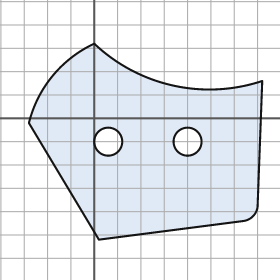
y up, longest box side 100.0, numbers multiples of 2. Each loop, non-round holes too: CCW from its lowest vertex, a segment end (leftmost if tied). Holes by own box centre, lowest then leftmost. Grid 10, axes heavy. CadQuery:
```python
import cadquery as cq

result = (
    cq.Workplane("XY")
    .moveTo(2.0, -52.0)
    .lineTo(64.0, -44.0)
    .threePointArc((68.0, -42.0), (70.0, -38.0))
    .lineTo(72.0, 16.0)
    .threePointArc((34.0, 14.0), (0.0, 32.0))
    .threePointArc((-18.0, 18.0), (-28.0, -2.0))
    .close()
    .moveTo(6.0, -10.0)
    .circle(6.0)
    .moveTo(40.0, -10.0)
    .circle(6.0)
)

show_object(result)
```